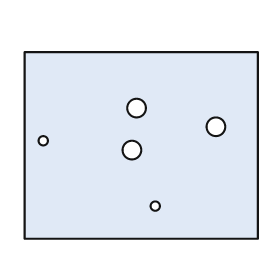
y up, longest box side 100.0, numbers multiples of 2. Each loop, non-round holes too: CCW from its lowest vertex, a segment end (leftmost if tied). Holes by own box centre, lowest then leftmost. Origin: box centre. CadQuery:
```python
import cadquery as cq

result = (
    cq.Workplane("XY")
    .moveTo(-50.0, -40.0)
    .lineTo(50.0, -40.0)
    .lineTo(50.0, 40.0)
    .lineTo(-50.0, 40.0)
    .close()
    .moveTo(6.0, -26.0)
    .circle(2.0)
    .moveTo(-4.0, -2.0)
    .circle(4.0)
    .moveTo(-42.0, 2.0)
    .circle(2.0)
    .moveTo(32.0, 8.0)
    .circle(4.0)
    .moveTo(-2.0, 16.0)
    .circle(4.0)
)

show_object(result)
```